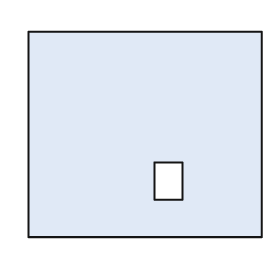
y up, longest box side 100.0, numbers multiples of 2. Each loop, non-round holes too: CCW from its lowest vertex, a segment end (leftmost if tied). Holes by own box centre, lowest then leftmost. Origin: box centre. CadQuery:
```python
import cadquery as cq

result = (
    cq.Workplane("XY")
    .moveTo(-50.0, -44.0)
    .lineTo(50.0, -44.0)
    .lineTo(50.0, 44.0)
    .lineTo(-50.0, 44.0)
    .close()
    .moveTo(4.0, -28.0)
    .lineTo(16.0, -28.0)
    .lineTo(16.0, -12.0)
    .lineTo(4.0, -12.0)
    .close()
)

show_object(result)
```